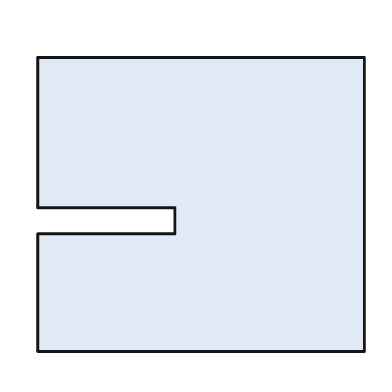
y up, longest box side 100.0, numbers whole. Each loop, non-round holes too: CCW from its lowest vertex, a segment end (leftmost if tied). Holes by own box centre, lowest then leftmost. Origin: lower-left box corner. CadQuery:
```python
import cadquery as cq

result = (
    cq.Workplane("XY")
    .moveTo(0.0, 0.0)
    .lineTo(100.0, 0.0)
    .lineTo(100.0, 90.0)
    .lineTo(0.0, 90.0)
    .lineTo(0.0, 44.0)
    .lineTo(42.0, 44.0)
    .lineTo(42.0, 36.0)
    .lineTo(0.0, 36.0)
    .close()
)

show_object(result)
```